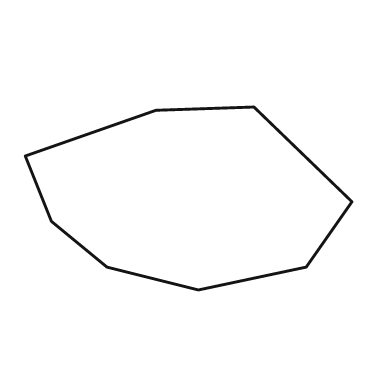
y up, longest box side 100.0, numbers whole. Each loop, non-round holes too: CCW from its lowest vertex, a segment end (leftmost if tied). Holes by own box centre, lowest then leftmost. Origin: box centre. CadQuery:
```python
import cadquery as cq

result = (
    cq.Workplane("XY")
    .moveTo(3.0, -28.0)
    .lineTo(36.0, -21.0)
    .lineTo(50.0, -1.0)
    .lineTo(20.0, 28.0)
    .lineTo(-10.0, 27.0)
    .lineTo(-50.0, 13.0)
    .lineTo(-42.0, -7.0)
    .lineTo(-25.0, -21.0)
    .close()
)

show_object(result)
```